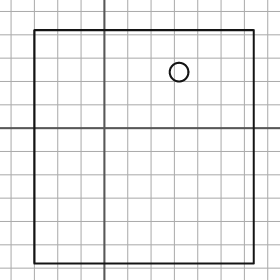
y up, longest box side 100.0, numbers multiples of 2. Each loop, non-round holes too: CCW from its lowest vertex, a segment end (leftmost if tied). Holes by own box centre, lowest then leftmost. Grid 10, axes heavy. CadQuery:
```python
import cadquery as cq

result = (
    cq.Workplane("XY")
    .moveTo(-30.0, -58.0)
    .lineTo(64.0, -58.0)
    .lineTo(64.0, 42.0)
    .lineTo(-30.0, 42.0)
    .close()
    .moveTo(32.0, 24.0)
    .circle(4.0)
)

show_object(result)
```